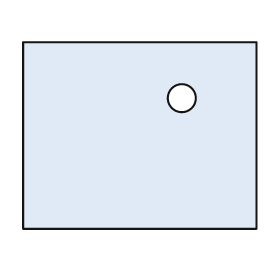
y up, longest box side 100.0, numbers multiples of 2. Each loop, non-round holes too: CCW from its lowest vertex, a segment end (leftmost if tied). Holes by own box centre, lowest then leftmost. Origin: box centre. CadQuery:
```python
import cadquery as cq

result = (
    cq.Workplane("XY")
    .moveTo(-50.0, -40.0)
    .lineTo(50.0, -40.0)
    .lineTo(50.0, 40.0)
    .lineTo(-50.0, 40.0)
    .close()
    .moveTo(18.0, 16.0)
    .circle(6.0)
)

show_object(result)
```